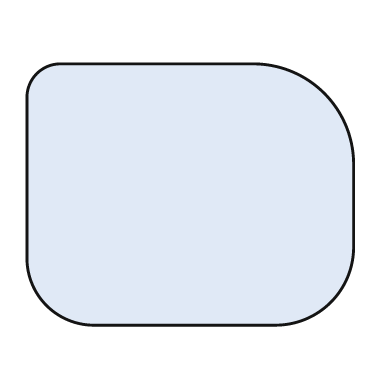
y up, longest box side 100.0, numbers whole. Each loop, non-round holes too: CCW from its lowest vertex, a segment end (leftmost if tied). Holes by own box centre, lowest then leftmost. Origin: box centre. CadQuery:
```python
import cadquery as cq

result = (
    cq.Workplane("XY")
    .moveTo(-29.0, -40.0)
    .lineTo(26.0, -40.0)
    .threePointArc((43.0, -33.0), (50.0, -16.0))
    .lineTo(50.0, 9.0)
    .threePointArc((41.0, 31.0), (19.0, 40.0))
    .lineTo(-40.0, 40.0)
    .threePointArc((-47.0, 37.0), (-50.0, 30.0))
    .lineTo(-50.0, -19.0)
    .threePointArc((-44.0, -34.0), (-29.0, -40.0))
    .close()
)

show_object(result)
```